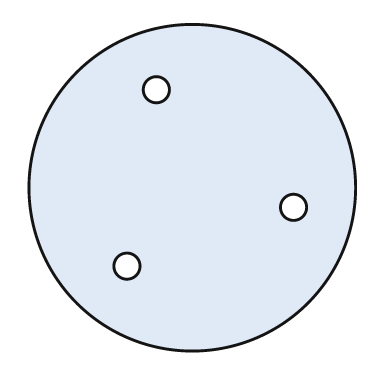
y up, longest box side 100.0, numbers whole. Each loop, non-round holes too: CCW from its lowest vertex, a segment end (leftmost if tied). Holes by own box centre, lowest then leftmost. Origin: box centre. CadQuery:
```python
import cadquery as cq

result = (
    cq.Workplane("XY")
    .moveTo(0.0, 0.0)
    .circle(50.0)
    .moveTo(-20.0, -24.0)
    .circle(4.0)
    .moveTo(31.0, -6.0)
    .circle(4.0)
    .moveTo(-11.0, 30.0)
    .circle(4.0)
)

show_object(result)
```